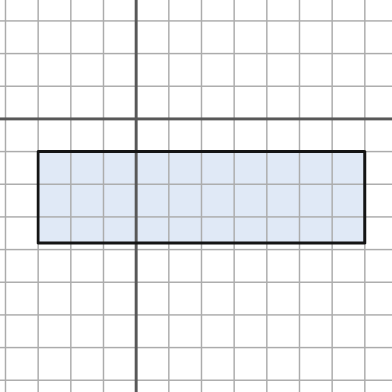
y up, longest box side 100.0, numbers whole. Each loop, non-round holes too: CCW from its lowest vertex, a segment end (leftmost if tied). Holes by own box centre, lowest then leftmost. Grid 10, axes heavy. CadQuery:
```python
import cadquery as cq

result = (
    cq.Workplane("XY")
    .moveTo(-30.0, -38.0)
    .lineTo(70.0, -38.0)
    .lineTo(70.0, -10.0)
    .lineTo(-30.0, -10.0)
    .close()
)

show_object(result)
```